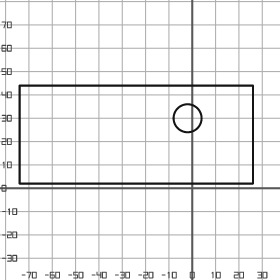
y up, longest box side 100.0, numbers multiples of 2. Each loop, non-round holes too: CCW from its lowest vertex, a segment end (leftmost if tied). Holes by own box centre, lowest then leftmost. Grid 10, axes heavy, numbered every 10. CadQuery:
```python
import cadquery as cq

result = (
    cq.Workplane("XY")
    .moveTo(-74.0, 2.0)
    .lineTo(26.0, 2.0)
    .lineTo(26.0, 44.0)
    .lineTo(-74.0, 44.0)
    .close()
    .moveTo(-2.0, 30.0)
    .circle(6.0)
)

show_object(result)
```